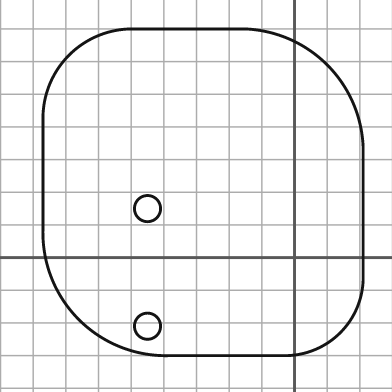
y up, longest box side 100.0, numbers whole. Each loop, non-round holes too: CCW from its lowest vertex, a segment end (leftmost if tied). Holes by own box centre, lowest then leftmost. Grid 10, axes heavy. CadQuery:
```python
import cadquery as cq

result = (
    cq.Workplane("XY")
    .moveTo(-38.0, -30.0)
    .lineTo(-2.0, -30.0)
    .threePointArc((14.0, -23.0), (21.0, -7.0))
    .lineTo(21.0, 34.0)
    .threePointArc((10.0, 59.0), (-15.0, 70.0))
    .lineTo(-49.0, 70.0)
    .threePointArc((-69.0, 62.0), (-77.0, 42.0))
    .lineTo(-77.0, 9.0)
    .threePointArc((-66.0, -19.0), (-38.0, -30.0))
    .close()
    .moveTo(-45.0, -21.0)
    .circle(4.0)
    .moveTo(-45.0, 15.0)
    .circle(4.0)
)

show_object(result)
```